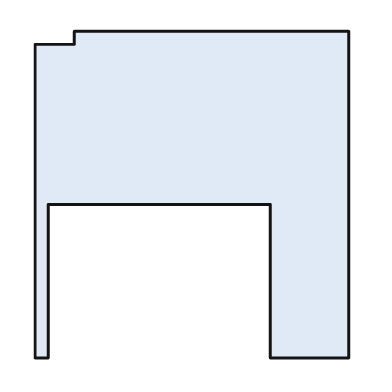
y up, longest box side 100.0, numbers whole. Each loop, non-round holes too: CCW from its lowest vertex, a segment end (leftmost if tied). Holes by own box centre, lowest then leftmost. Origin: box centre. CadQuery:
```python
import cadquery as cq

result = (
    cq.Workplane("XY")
    .moveTo(-48.0, -50.0)
    .lineTo(-44.0, -50.0)
    .lineTo(-44.0, -3.0)
    .lineTo(24.0, -3.0)
    .lineTo(24.0, -50.0)
    .lineTo(48.0, -50.0)
    .lineTo(48.0, 50.0)
    .lineTo(-36.0, 50.0)
    .lineTo(-36.0, 46.0)
    .lineTo(-48.0, 46.0)
    .close()
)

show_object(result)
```